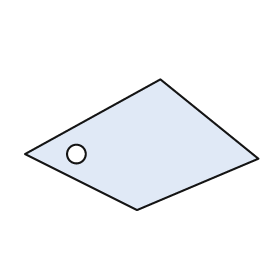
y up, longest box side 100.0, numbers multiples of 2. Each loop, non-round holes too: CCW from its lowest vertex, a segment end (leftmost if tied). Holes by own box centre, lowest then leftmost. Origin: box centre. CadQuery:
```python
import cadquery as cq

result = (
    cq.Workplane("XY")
    .moveTo(-2.0, -28.0)
    .lineTo(50.0, -6.0)
    .lineTo(8.0, 28.0)
    .lineTo(-50.0, -4.0)
    .close()
    .moveTo(-28.0, -4.0)
    .circle(4.0)
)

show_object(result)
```